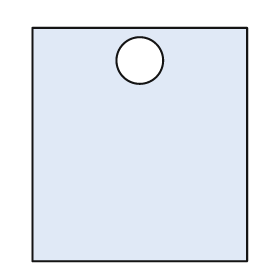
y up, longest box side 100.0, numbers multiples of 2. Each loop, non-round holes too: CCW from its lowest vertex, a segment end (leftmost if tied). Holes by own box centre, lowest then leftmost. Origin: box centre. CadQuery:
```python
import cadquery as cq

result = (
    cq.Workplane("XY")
    .moveTo(-46.0, -50.0)
    .lineTo(46.0, -50.0)
    .lineTo(46.0, 50.0)
    .lineTo(-46.0, 50.0)
    .close()
    .moveTo(0.0, 36.0)
    .circle(10.0)
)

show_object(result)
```